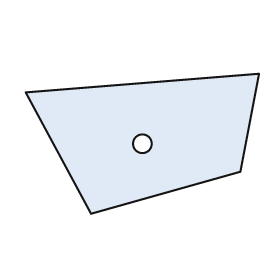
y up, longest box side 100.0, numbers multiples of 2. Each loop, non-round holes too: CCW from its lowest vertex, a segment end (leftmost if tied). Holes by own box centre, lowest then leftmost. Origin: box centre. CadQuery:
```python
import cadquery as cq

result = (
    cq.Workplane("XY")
    .moveTo(-22.0, -30.0)
    .lineTo(42.0, -12.0)
    .lineTo(50.0, 30.0)
    .lineTo(-50.0, 22.0)
    .close()
    .moveTo(0.0, 0.0)
    .circle(4.0)
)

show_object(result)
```